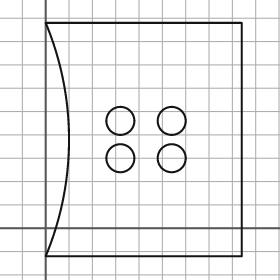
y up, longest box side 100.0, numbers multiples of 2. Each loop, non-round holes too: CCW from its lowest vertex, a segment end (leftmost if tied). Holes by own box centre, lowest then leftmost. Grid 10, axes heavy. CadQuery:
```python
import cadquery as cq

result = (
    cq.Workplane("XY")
    .moveTo(0.0, -12.0)
    .lineTo(84.0, -12.0)
    .lineTo(84.0, 88.0)
    .lineTo(0.0, 88.0)
    .threePointArc((10.0, 38.0), (0.0, -12.0))
    .close()
    .moveTo(32.0, 30.0)
    .circle(6.0)
    .moveTo(54.0, 30.0)
    .circle(6.0)
    .moveTo(32.0, 46.0)
    .circle(6.0)
    .moveTo(54.0, 46.0)
    .circle(6.0)
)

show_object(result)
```